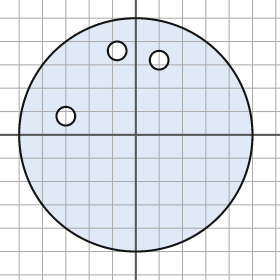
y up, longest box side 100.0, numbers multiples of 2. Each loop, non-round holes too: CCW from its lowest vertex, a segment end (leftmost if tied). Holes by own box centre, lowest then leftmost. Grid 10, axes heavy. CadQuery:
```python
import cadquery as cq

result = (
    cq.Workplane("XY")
    .moveTo(0.0, 0.0)
    .circle(50.0)
    .moveTo(-30.0, 8.0)
    .circle(4.0)
    .moveTo(10.0, 32.0)
    .circle(4.0)
    .moveTo(-8.0, 36.0)
    .circle(4.0)
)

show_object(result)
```